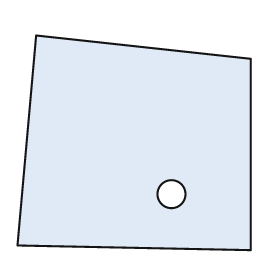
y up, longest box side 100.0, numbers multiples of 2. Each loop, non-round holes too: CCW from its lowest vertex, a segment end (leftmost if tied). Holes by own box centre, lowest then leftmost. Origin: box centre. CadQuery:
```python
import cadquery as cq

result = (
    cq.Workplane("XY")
    .moveTo(50.0, -46.0)
    .lineTo(50.0, 36.0)
    .lineTo(-42.0, 46.0)
    .lineTo(-50.0, -44.0)
    .close()
    .moveTo(16.0, -22.0)
    .circle(6.0)
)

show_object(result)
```